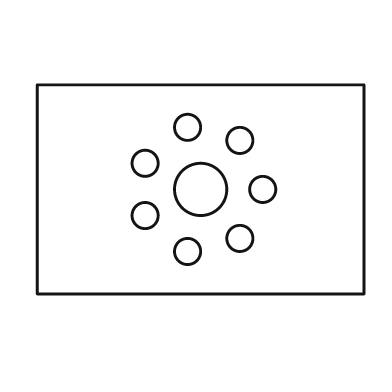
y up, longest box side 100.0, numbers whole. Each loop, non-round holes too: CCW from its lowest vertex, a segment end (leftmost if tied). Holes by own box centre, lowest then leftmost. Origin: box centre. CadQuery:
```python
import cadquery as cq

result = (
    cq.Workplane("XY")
    .moveTo(-50.0, -32.0)
    .lineTo(50.0, -32.0)
    .lineTo(50.0, 32.0)
    .lineTo(-50.0, 32.0)
    .close()
    .moveTo(-4.0, -19.0)
    .circle(4.0)
    .moveTo(12.0, -15.0)
    .circle(4.0)
    .moveTo(-17.0, -8.0)
    .circle(4.0)
    .moveTo(0.0, 0.0)
    .circle(8.0)
    .moveTo(19.0, 0.0)
    .circle(4.0)
    .moveTo(-17.0, 8.0)
    .circle(4.0)
    .moveTo(12.0, 15.0)
    .circle(4.0)
    .moveTo(-4.0, 19.0)
    .circle(4.0)
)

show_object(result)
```